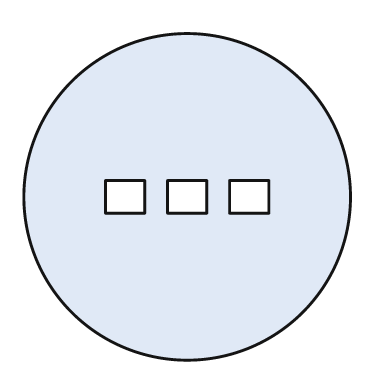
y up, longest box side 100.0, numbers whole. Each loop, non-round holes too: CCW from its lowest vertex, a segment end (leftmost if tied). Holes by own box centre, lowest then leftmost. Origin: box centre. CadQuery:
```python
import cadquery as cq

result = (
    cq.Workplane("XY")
    .moveTo(0.0, 0.0)
    .circle(50.0)
    .moveTo(-25.0, -5.0)
    .lineTo(-13.0, -5.0)
    .lineTo(-13.0, 5.0)
    .lineTo(-25.0, 5.0)
    .close()
    .moveTo(-6.0, -5.0)
    .lineTo(6.0, -5.0)
    .lineTo(6.0, 5.0)
    .lineTo(-6.0, 5.0)
    .close()
    .moveTo(13.0, -5.0)
    .lineTo(25.0, -5.0)
    .lineTo(25.0, 5.0)
    .lineTo(13.0, 5.0)
    .close()
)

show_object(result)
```